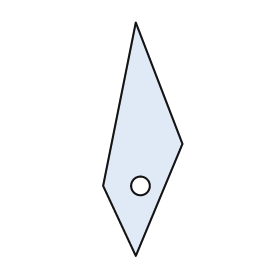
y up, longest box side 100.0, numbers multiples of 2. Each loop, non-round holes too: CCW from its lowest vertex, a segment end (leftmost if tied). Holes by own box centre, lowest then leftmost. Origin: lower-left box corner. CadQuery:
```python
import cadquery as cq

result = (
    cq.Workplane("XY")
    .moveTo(14.0, 0.0)
    .lineTo(34.0, 48.0)
    .lineTo(14.0, 100.0)
    .lineTo(0.0, 30.0)
    .close()
    .moveTo(16.0, 30.0)
    .circle(4.0)
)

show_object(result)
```